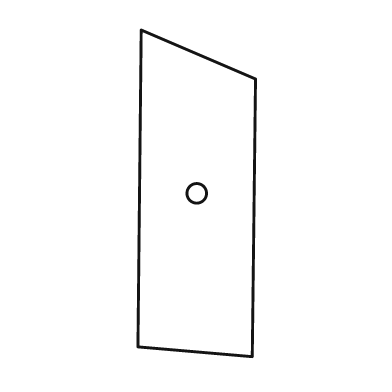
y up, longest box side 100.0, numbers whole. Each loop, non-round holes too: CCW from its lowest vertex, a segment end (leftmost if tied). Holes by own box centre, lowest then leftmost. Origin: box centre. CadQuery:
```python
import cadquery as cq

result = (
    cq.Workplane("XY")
    .moveTo(17.0, -50.0)
    .lineTo(18.0, 35.0)
    .lineTo(-17.0, 50.0)
    .lineTo(-18.0, -47.0)
    .close()
    .moveTo(0.0, 0.0)
    .circle(3.0)
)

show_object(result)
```